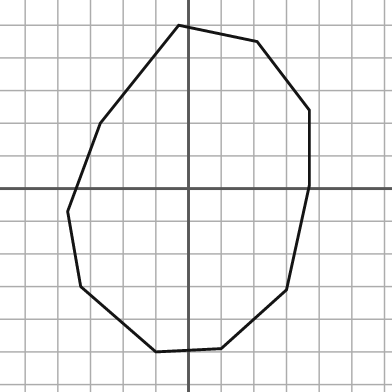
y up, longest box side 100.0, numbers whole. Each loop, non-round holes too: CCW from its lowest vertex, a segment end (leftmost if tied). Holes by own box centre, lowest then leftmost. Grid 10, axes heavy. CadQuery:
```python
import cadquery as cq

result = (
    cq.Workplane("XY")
    .moveTo(-10.0, -50.0)
    .lineTo(10.0, -49.0)
    .lineTo(30.0, -31.0)
    .lineTo(37.0, 1.0)
    .lineTo(37.0, 24.0)
    .lineTo(21.0, 45.0)
    .lineTo(-3.0, 50.0)
    .lineTo(-27.0, 20.0)
    .lineTo(-37.0, -7.0)
    .lineTo(-33.0, -30.0)
    .close()
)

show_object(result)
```